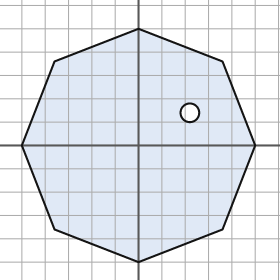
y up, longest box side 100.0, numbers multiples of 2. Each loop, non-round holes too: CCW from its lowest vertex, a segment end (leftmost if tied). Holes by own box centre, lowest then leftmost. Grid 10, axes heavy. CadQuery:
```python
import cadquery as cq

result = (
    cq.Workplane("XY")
    .moveTo(0.0, -50.0)
    .lineTo(36.0, -36.0)
    .lineTo(50.0, 0.0)
    .lineTo(36.0, 36.0)
    .lineTo(0.0, 50.0)
    .lineTo(-36.0, 36.0)
    .lineTo(-50.0, 0.0)
    .lineTo(-36.0, -36.0)
    .close()
    .moveTo(22.0, 14.0)
    .circle(4.0)
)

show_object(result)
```